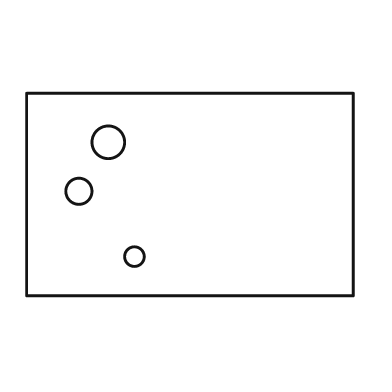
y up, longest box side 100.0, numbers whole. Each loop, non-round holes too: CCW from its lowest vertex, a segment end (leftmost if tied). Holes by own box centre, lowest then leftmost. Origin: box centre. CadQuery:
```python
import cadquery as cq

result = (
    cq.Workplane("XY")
    .moveTo(-50.0, -31.0)
    .lineTo(50.0, -31.0)
    .lineTo(50.0, 31.0)
    .lineTo(-50.0, 31.0)
    .close()
    .moveTo(-17.0, -19.0)
    .circle(3.0)
    .moveTo(-34.0, 1.0)
    .circle(4.0)
    .moveTo(-25.0, 16.0)
    .circle(5.0)
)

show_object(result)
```